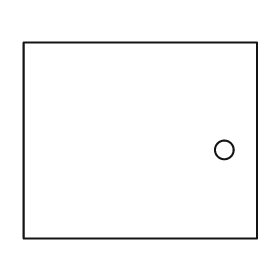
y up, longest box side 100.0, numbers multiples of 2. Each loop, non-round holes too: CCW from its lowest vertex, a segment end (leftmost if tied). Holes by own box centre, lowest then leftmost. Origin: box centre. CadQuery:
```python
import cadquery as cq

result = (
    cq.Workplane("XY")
    .moveTo(-50.0, -42.0)
    .lineTo(50.0, -42.0)
    .lineTo(50.0, 42.0)
    .lineTo(-50.0, 42.0)
    .close()
    .moveTo(36.0, -4.0)
    .circle(4.0)
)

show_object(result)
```